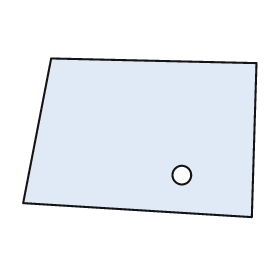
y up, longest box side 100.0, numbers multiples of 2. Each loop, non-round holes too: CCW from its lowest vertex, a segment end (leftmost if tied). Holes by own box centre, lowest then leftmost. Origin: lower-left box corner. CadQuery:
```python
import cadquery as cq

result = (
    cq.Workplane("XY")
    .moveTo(98.0, 0.0)
    .lineTo(100.0, 66.0)
    .lineTo(12.0, 68.0)
    .lineTo(0.0, 6.0)
    .close()
    .moveTo(68.0, 18.0)
    .circle(4.0)
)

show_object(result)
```